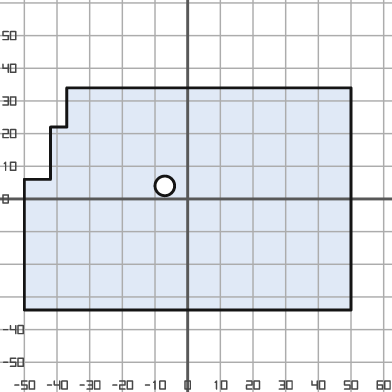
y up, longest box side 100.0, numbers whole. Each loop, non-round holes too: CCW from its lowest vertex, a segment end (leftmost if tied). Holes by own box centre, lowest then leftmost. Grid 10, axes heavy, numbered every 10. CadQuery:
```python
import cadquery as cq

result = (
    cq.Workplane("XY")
    .moveTo(-50.0, -34.0)
    .lineTo(50.0, -34.0)
    .lineTo(50.0, 34.0)
    .lineTo(-37.0, 34.0)
    .lineTo(-37.0, 22.0)
    .lineTo(-42.0, 22.0)
    .lineTo(-42.0, 6.0)
    .lineTo(-50.0, 6.0)
    .close()
    .moveTo(-7.0, 4.0)
    .circle(3.0)
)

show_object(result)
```